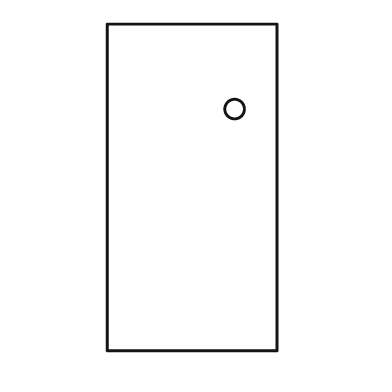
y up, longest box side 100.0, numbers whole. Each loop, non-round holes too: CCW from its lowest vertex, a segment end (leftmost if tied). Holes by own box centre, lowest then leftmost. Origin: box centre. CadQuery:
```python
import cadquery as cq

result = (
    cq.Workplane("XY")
    .moveTo(-26.0, -50.0)
    .lineTo(26.0, -50.0)
    .lineTo(26.0, 50.0)
    .lineTo(-26.0, 50.0)
    .close()
    .moveTo(13.0, 24.0)
    .circle(3.0)
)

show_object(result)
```